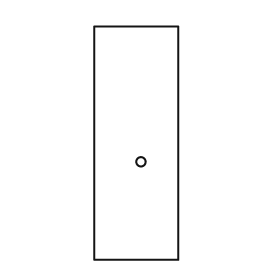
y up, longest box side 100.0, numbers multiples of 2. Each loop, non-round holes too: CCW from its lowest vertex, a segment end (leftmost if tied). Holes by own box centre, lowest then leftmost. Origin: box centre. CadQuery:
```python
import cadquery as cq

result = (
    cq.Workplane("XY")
    .moveTo(-18.0, -50.0)
    .lineTo(18.0, -50.0)
    .lineTo(18.0, 50.0)
    .lineTo(-18.0, 50.0)
    .close()
    .moveTo(2.0, -8.0)
    .circle(2.0)
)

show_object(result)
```